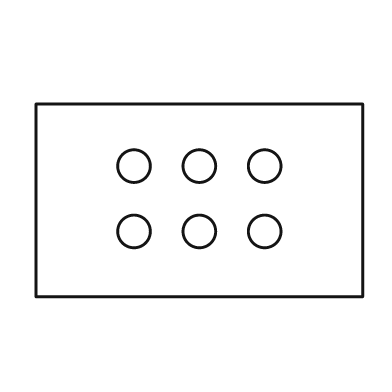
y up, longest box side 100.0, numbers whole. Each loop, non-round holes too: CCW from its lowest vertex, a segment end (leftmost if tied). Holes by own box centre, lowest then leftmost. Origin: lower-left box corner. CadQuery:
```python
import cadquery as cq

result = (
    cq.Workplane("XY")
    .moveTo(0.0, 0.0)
    .lineTo(100.0, 0.0)
    .lineTo(100.0, 59.0)
    .lineTo(0.0, 59.0)
    .close()
    .moveTo(30.0, 20.0)
    .circle(5.0)
    .moveTo(50.0, 20.0)
    .circle(5.0)
    .moveTo(70.0, 20.0)
    .circle(5.0)
    .moveTo(30.0, 40.0)
    .circle(5.0)
    .moveTo(50.0, 40.0)
    .circle(5.0)
    .moveTo(70.0, 40.0)
    .circle(5.0)
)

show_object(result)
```